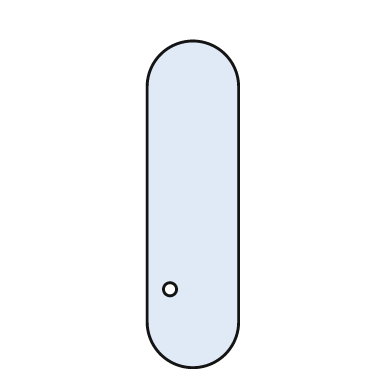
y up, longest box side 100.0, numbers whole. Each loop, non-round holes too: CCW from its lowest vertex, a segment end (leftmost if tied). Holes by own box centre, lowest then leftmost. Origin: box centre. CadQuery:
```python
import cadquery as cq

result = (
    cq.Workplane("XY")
    .moveTo(-14.0, -36.0)
    .threePointArc((0.0, -50.0), (14.0, -36.0))
    .lineTo(14.0, 36.0)
    .threePointArc((0.0, 50.0), (-14.0, 36.0))
    .close()
    .moveTo(-7.0, -26.0)
    .circle(2.0)
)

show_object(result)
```